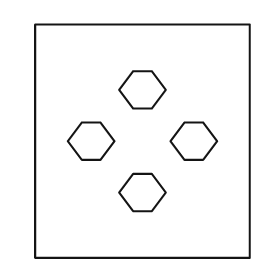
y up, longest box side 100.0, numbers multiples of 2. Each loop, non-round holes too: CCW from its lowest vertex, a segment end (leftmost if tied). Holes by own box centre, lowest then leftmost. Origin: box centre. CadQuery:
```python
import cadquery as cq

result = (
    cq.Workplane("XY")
    .moveTo(-46.0, -50.0)
    .lineTo(46.0, -50.0)
    .lineTo(46.0, 50.0)
    .lineTo(-46.0, 50.0)
    .close()
    .moveTo(-4.0, -30.0)
    .lineTo(4.0, -30.0)
    .lineTo(10.0, -22.0)
    .lineTo(4.0, -14.0)
    .lineTo(-4.0, -14.0)
    .lineTo(-10.0, -22.0)
    .close()
    .moveTo(-26.0, -8.0)
    .lineTo(-18.0, -8.0)
    .lineTo(-12.0, 0.0)
    .lineTo(-18.0, 8.0)
    .lineTo(-26.0, 8.0)
    .lineTo(-32.0, 0.0)
    .close()
    .moveTo(18.0, -8.0)
    .lineTo(26.0, -8.0)
    .lineTo(32.0, 0.0)
    .lineTo(26.0, 8.0)
    .lineTo(18.0, 8.0)
    .lineTo(12.0, 0.0)
    .close()
    .moveTo(-4.0, 14.0)
    .lineTo(4.0, 14.0)
    .lineTo(10.0, 22.0)
    .lineTo(4.0, 30.0)
    .lineTo(-4.0, 30.0)
    .lineTo(-10.0, 22.0)
    .close()
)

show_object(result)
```